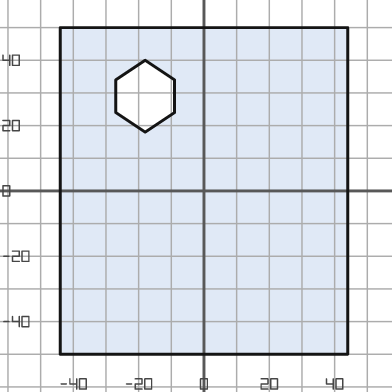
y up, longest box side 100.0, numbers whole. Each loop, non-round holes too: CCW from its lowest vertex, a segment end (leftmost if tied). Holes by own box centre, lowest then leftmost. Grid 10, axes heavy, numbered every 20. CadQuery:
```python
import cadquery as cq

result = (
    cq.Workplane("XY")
    .moveTo(-44.0, -50.0)
    .lineTo(44.0, -50.0)
    .lineTo(44.0, 50.0)
    .lineTo(-44.0, 50.0)
    .close()
    .moveTo(-18.0, 18.0)
    .lineTo(-9.0, 24.0)
    .lineTo(-9.0, 34.0)
    .lineTo(-18.0, 40.0)
    .lineTo(-27.0, 34.0)
    .lineTo(-27.0, 24.0)
    .close()
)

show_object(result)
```